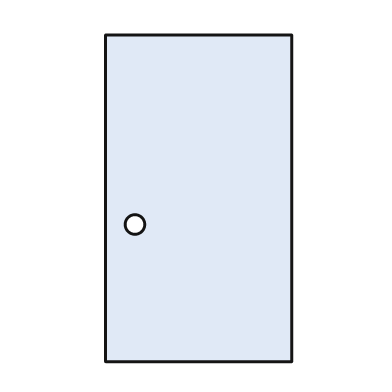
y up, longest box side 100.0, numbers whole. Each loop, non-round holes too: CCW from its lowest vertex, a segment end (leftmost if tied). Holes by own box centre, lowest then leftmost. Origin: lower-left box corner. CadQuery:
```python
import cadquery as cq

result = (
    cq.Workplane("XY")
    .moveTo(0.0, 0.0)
    .lineTo(57.0, 0.0)
    .lineTo(57.0, 100.0)
    .lineTo(0.0, 100.0)
    .close()
    .moveTo(9.0, 42.0)
    .circle(3.0)
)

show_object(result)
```